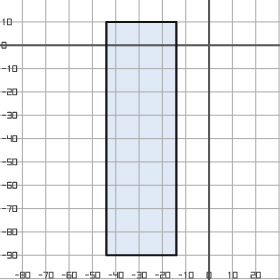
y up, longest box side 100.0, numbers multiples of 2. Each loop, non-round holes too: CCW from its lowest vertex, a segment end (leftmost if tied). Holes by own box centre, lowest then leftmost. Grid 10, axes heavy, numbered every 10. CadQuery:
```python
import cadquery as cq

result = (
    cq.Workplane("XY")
    .moveTo(-44.0, -90.0)
    .lineTo(-14.0, -90.0)
    .lineTo(-14.0, 10.0)
    .lineTo(-44.0, 10.0)
    .close()
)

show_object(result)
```